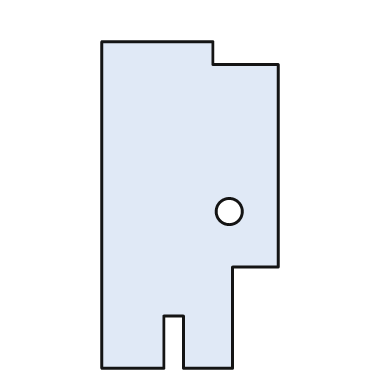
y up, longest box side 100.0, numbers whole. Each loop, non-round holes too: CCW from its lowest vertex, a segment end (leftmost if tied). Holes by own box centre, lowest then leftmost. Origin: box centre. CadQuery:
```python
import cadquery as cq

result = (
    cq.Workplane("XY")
    .moveTo(-27.0, -50.0)
    .lineTo(-8.0, -50.0)
    .lineTo(-8.0, -34.0)
    .lineTo(-2.0, -34.0)
    .lineTo(-2.0, -50.0)
    .lineTo(13.0, -50.0)
    .lineTo(13.0, -19.0)
    .lineTo(27.0, -19.0)
    .lineTo(27.0, 43.0)
    .lineTo(7.0, 43.0)
    .lineTo(7.0, 50.0)
    .lineTo(-27.0, 50.0)
    .close()
    .moveTo(12.0, -2.0)
    .circle(4.0)
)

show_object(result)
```